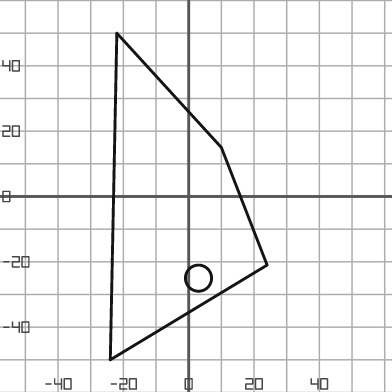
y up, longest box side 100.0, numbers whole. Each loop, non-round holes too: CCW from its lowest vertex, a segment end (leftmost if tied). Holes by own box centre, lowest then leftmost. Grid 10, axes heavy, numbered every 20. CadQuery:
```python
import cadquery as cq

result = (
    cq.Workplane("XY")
    .moveTo(-24.0, -50.0)
    .lineTo(24.0, -21.0)
    .lineTo(10.0, 15.0)
    .lineTo(-22.0, 50.0)
    .close()
    .moveTo(3.0, -25.0)
    .circle(4.0)
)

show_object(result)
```